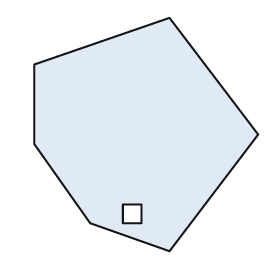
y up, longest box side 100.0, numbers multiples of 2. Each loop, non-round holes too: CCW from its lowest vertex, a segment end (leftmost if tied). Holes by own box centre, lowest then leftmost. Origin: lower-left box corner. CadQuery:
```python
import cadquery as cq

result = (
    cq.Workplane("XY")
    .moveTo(58.0, 0.0)
    .lineTo(96.0, 50.0)
    .lineTo(58.0, 100.0)
    .lineTo(0.0, 80.0)
    .lineTo(0.0, 46.0)
    .lineTo(24.0, 12.0)
    .close()
    .moveTo(38.0, 12.0)
    .lineTo(46.0, 12.0)
    .lineTo(46.0, 20.0)
    .lineTo(38.0, 20.0)
    .close()
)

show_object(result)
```